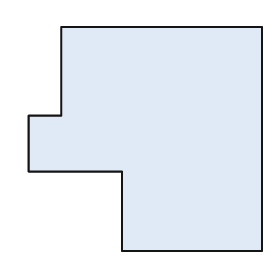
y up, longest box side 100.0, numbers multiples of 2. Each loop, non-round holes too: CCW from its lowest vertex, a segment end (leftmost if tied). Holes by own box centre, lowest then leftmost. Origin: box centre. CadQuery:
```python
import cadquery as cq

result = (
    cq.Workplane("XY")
    .moveTo(-10.0, -48.0)
    .lineTo(50.0, -48.0)
    .lineTo(50.0, 48.0)
    .lineTo(-36.0, 48.0)
    .lineTo(-36.0, 10.0)
    .lineTo(-50.0, 10.0)
    .lineTo(-50.0, -14.0)
    .lineTo(-10.0, -14.0)
    .close()
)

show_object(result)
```